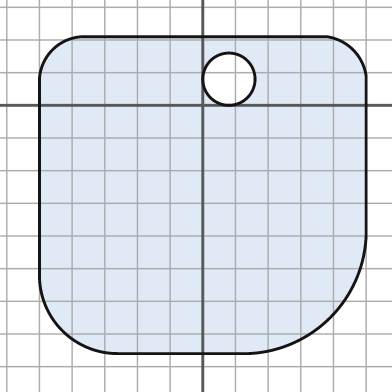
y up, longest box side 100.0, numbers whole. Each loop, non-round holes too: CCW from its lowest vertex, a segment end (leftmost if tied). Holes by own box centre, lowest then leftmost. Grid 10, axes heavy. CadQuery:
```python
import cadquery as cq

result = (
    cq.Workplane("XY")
    .moveTo(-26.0, -76.0)
    .lineTo(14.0, -76.0)
    .threePointArc((39.0, -65.0), (50.0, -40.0))
    .lineTo(50.0, 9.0)
    .threePointArc((46.0, 17.0), (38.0, 21.0))
    .lineTo(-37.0, 21.0)
    .threePointArc((-46.0, 17.0), (-50.0, 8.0))
    .lineTo(-50.0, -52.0)
    .threePointArc((-43.0, -69.0), (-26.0, -76.0))
    .close()
    .moveTo(8.0, 8.0)
    .circle(8.0)
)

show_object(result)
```